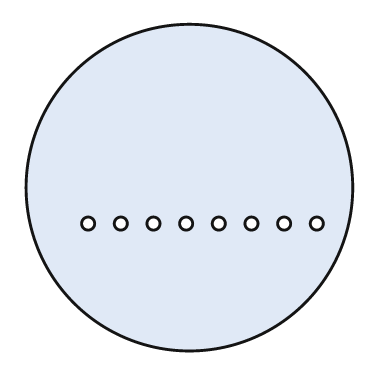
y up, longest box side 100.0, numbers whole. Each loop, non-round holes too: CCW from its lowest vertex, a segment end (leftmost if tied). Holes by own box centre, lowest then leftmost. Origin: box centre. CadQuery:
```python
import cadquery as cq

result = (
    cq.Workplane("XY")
    .moveTo(0.0, 0.0)
    .circle(50.0)
    .moveTo(-31.0, -11.0)
    .circle(2.0)
    .moveTo(-21.0, -11.0)
    .circle(2.0)
    .moveTo(-11.0, -11.0)
    .circle(2.0)
    .moveTo(-1.0, -11.0)
    .circle(2.0)
    .moveTo(9.0, -11.0)
    .circle(2.0)
    .moveTo(19.0, -11.0)
    .circle(2.0)
    .moveTo(29.0, -11.0)
    .circle(2.0)
    .moveTo(39.0, -11.0)
    .circle(2.0)
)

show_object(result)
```